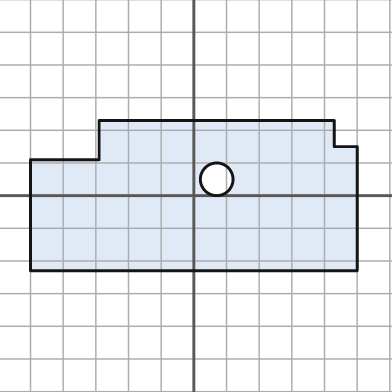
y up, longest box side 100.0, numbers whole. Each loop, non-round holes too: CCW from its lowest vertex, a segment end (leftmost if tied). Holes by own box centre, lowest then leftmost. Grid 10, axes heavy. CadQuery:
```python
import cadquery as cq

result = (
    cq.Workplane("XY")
    .moveTo(-50.0, -23.0)
    .lineTo(50.0, -23.0)
    .lineTo(50.0, 15.0)
    .lineTo(43.0, 15.0)
    .lineTo(43.0, 23.0)
    .lineTo(-29.0, 23.0)
    .lineTo(-29.0, 11.0)
    .lineTo(-50.0, 11.0)
    .close()
    .moveTo(7.0, 5.0)
    .circle(5.0)
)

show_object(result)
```